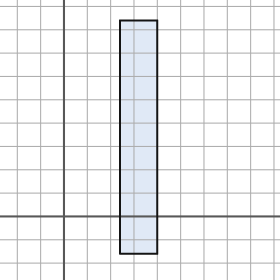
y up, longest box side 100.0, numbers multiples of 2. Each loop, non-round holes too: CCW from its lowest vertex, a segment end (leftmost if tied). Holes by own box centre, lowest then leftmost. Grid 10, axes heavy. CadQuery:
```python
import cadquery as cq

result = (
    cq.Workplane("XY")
    .moveTo(24.0, -16.0)
    .lineTo(40.0, -16.0)
    .lineTo(40.0, 84.0)
    .lineTo(24.0, 84.0)
    .close()
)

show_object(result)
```